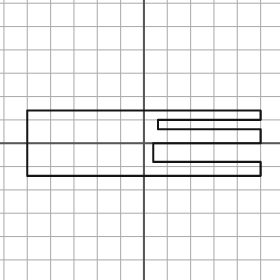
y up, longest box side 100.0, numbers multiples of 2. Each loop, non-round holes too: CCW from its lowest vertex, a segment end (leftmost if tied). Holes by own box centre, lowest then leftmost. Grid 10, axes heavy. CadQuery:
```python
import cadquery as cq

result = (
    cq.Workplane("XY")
    .moveTo(-50.0, -14.0)
    .lineTo(50.0, -14.0)
    .lineTo(50.0, -8.0)
    .lineTo(4.0, -8.0)
    .lineTo(4.0, 0.0)
    .lineTo(50.0, 0.0)
    .lineTo(50.0, 6.0)
    .lineTo(6.0, 6.0)
    .lineTo(6.0, 10.0)
    .lineTo(50.0, 10.0)
    .lineTo(50.0, 14.0)
    .lineTo(-50.0, 14.0)
    .close()
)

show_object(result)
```